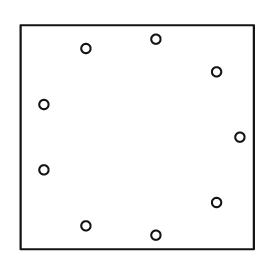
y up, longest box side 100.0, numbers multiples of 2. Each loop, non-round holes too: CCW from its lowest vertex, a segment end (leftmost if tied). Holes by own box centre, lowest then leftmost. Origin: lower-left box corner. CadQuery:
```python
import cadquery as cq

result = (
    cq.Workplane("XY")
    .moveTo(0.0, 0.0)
    .lineTo(100.0, 0.0)
    .lineTo(100.0, 96.0)
    .lineTo(0.0, 96.0)
    .close()
    .moveTo(58.0, 6.0)
    .circle(2.0)
    .moveTo(28.0, 10.0)
    .circle(2.0)
    .moveTo(84.0, 20.0)
    .circle(2.0)
    .moveTo(10.0, 34.0)
    .circle(2.0)
    .moveTo(94.0, 48.0)
    .circle(2.0)
    .moveTo(10.0, 62.0)
    .circle(2.0)
    .moveTo(84.0, 76.0)
    .circle(2.0)
    .moveTo(28.0, 86.0)
    .circle(2.0)
    .moveTo(58.0, 90.0)
    .circle(2.0)
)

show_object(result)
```